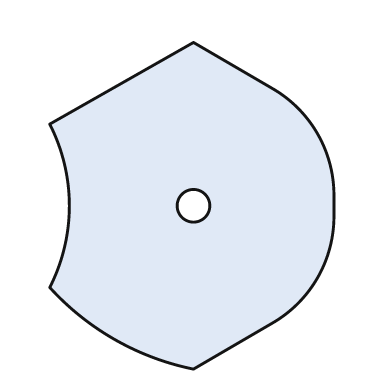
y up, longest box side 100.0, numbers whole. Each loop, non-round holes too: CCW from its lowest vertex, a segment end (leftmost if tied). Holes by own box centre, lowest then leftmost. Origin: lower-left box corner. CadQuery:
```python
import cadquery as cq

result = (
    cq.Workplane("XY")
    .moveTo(44.0, 0.0)
    .lineTo(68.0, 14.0)
    .threePointArc((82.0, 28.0), (87.0, 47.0))
    .lineTo(87.0, 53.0)
    .threePointArc((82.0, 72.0), (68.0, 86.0))
    .lineTo(44.0, 100.0)
    .lineTo(0.0, 75.0)
    .threePointArc((6.0, 50.0), (0.0, 25.0))
    .threePointArc((20.0, 9.0), (44.0, 0.0))
    .close()
    .moveTo(44.0, 50.0)
    .circle(5.0)
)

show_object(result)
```